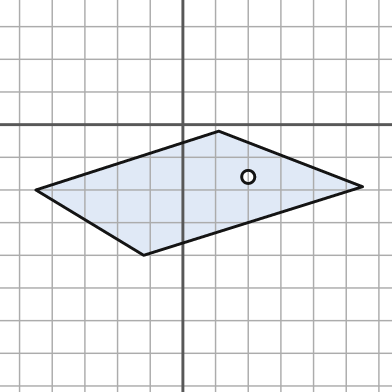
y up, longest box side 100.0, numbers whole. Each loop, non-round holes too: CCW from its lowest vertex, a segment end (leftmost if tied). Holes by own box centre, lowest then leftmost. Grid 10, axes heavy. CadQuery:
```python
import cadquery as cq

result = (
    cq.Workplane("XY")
    .moveTo(-12.0, -40.0)
    .lineTo(55.0, -19.0)
    .lineTo(11.0, -2.0)
    .lineTo(-45.0, -20.0)
    .close()
    .moveTo(20.0, -16.0)
    .circle(2.0)
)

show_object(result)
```